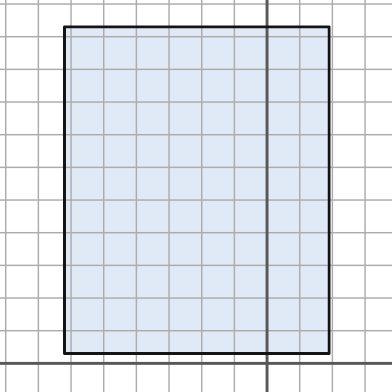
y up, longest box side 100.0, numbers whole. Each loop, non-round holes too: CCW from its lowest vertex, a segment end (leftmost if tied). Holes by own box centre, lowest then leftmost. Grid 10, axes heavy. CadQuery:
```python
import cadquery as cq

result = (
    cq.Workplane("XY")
    .moveTo(-62.0, 3.0)
    .lineTo(19.0, 3.0)
    .lineTo(19.0, 103.0)
    .lineTo(-62.0, 103.0)
    .close()
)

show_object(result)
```